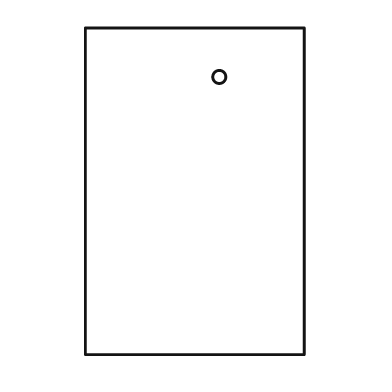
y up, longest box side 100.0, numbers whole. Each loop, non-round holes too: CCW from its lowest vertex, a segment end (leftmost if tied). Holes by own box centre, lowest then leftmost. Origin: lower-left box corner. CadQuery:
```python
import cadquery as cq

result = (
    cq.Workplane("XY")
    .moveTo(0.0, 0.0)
    .lineTo(67.0, 0.0)
    .lineTo(67.0, 100.0)
    .lineTo(0.0, 100.0)
    .close()
    .moveTo(41.0, 85.0)
    .circle(2.0)
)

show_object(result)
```